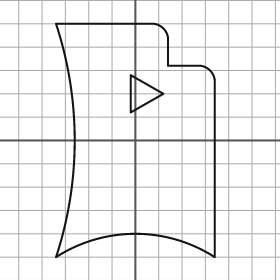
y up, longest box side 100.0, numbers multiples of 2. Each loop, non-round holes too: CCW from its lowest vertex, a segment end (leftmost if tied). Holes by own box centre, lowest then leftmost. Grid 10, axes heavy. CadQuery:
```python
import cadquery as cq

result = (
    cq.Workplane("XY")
    .moveTo(-34.0, -50.0)
    .threePointArc((0.0, -40.0), (34.0, -50.0))
    .lineTo(34.0, 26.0)
    .threePointArc((32.0, 30.0), (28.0, 32.0))
    .lineTo(14.0, 32.0)
    .lineTo(14.0, 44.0)
    .threePointArc((12.0, 48.0), (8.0, 50.0))
    .lineTo(-34.0, 50.0)
    .threePointArc((-26.0, 0.0), (-34.0, -50.0))
    .close()
    .moveTo(-2.0, 12.0)
    .lineTo(12.0, 20.0)
    .lineTo(-2.0, 28.0)
    .close()
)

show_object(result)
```